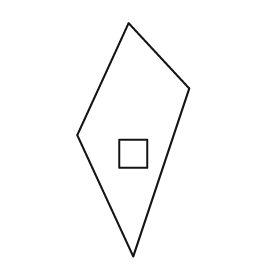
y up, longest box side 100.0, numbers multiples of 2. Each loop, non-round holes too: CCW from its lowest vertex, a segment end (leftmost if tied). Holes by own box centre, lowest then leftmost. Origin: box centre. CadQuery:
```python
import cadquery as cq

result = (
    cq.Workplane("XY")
    .moveTo(0.0, -50.0)
    .lineTo(24.0, 22.0)
    .lineTo(-2.0, 50.0)
    .lineTo(-24.0, 2.0)
    .close()
    .moveTo(-6.0, -12.0)
    .lineTo(6.0, -12.0)
    .lineTo(6.0, 0.0)
    .lineTo(-6.0, 0.0)
    .close()
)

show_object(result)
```